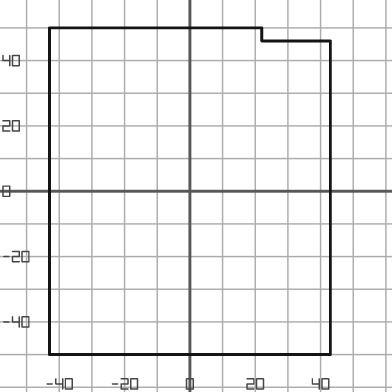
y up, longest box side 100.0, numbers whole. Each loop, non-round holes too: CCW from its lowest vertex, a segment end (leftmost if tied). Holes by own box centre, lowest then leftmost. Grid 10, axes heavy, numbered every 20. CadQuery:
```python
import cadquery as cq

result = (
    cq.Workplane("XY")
    .moveTo(-43.0, -50.0)
    .lineTo(43.0, -50.0)
    .lineTo(43.0, 46.0)
    .lineTo(22.0, 46.0)
    .lineTo(22.0, 50.0)
    .lineTo(-43.0, 50.0)
    .close()
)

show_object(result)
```